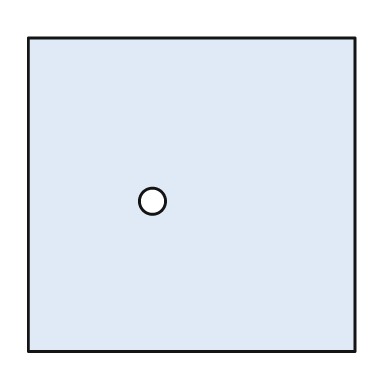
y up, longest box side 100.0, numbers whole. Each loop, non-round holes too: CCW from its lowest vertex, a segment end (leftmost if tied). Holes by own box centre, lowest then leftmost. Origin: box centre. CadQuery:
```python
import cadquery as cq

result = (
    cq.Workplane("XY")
    .moveTo(-50.0, -48.0)
    .lineTo(50.0, -48.0)
    .lineTo(50.0, 48.0)
    .lineTo(-50.0, 48.0)
    .close()
    .moveTo(-12.0, -2.0)
    .circle(4.0)
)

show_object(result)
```